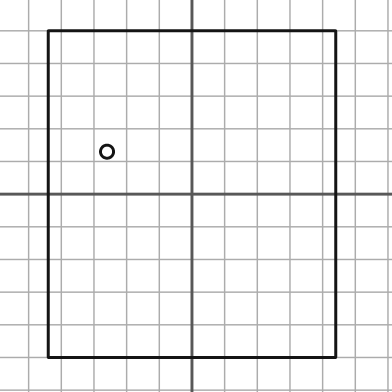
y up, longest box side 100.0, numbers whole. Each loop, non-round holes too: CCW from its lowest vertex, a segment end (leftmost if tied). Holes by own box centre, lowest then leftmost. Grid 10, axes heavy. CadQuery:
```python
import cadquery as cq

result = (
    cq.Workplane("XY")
    .moveTo(-44.0, -50.0)
    .lineTo(44.0, -50.0)
    .lineTo(44.0, 50.0)
    .lineTo(-44.0, 50.0)
    .close()
    .moveTo(-26.0, 13.0)
    .circle(2.0)
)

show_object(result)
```